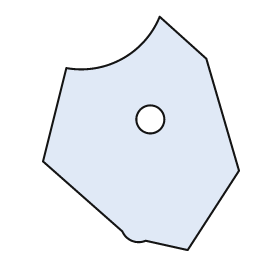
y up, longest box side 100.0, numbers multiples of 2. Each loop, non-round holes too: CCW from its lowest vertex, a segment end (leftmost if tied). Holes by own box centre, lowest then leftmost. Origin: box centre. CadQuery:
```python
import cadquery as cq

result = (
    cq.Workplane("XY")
    .moveTo(20.0, -50.0)
    .lineTo(42.0, -16.0)
    .lineTo(28.0, 32.0)
    .lineTo(8.0, 50.0)
    .threePointArc((-8.0, 32.0), (-32.0, 28.0))
    .lineTo(-42.0, -12.0)
    .lineTo(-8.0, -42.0)
    .threePointArc((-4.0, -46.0), (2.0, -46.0))
    .close()
    .moveTo(4.0, 6.0)
    .circle(6.0)
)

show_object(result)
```